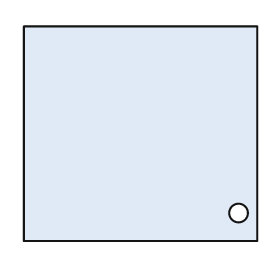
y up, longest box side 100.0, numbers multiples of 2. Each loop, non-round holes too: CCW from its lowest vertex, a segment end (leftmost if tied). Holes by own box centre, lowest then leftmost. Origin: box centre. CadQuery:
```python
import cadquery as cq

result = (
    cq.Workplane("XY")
    .moveTo(-50.0, -46.0)
    .lineTo(50.0, -46.0)
    .lineTo(50.0, 46.0)
    .lineTo(-50.0, 46.0)
    .close()
    .moveTo(42.0, -34.0)
    .circle(4.0)
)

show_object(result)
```